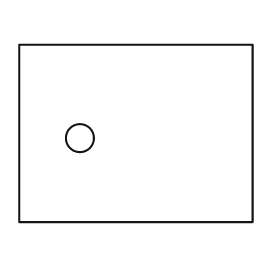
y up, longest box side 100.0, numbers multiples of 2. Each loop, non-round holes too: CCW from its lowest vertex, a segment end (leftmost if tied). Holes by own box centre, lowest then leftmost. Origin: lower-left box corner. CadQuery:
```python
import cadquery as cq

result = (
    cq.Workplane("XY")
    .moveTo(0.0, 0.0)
    .lineTo(100.0, 0.0)
    .lineTo(100.0, 76.0)
    .lineTo(0.0, 76.0)
    .close()
    .moveTo(26.0, 36.0)
    .circle(6.0)
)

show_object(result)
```